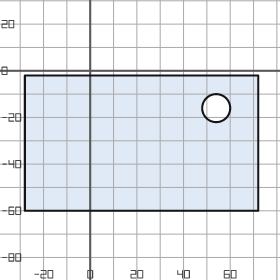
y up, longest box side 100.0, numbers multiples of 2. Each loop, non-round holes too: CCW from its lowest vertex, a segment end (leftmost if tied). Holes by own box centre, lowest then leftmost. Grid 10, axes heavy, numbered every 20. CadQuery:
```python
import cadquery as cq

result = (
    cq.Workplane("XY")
    .moveTo(-28.0, -60.0)
    .lineTo(72.0, -60.0)
    .lineTo(72.0, -2.0)
    .lineTo(-28.0, -2.0)
    .close()
    .moveTo(54.0, -16.0)
    .circle(6.0)
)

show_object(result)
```